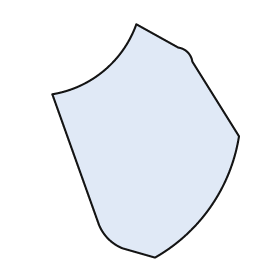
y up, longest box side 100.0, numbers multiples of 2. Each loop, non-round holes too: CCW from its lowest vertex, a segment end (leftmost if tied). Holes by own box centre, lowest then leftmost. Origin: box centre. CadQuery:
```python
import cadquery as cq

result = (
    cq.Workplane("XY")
    .moveTo(4.0, -50.0)
    .threePointArc((28.0, -28.0), (40.0, 2.0))
    .lineTo(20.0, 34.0)
    .threePointArc((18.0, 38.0), (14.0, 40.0))
    .lineTo(-4.0, 50.0)
    .threePointArc((-18.0, 30.0), (-40.0, 20.0))
    .lineTo(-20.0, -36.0)
    .threePointArc((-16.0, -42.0), (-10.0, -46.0))
    .close()
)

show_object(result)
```